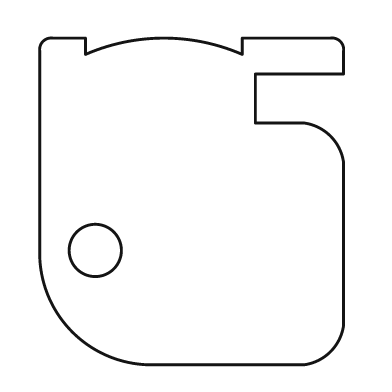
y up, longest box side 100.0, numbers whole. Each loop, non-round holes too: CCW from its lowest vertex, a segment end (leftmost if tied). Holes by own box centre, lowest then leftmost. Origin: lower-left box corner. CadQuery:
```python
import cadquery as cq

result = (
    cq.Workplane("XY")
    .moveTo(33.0, 0.0)
    .lineTo(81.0, 0.0)
    .threePointArc((89.0, 4.0), (93.0, 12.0))
    .lineTo(93.0, 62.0)
    .threePointArc((89.0, 70.0), (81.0, 74.0))
    .lineTo(66.0, 74.0)
    .lineTo(66.0, 89.0)
    .lineTo(93.0, 89.0)
    .lineTo(93.0, 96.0)
    .threePointArc((92.0, 99.0), (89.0, 100.0))
    .lineTo(62.0, 100.0)
    .lineTo(62.0, 95.0)
    .threePointArc((38.0, 100.0), (14.0, 95.0))
    .lineTo(14.0, 100.0)
    .lineTo(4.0, 100.0)
    .threePointArc((1.0, 99.0), (0.0, 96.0))
    .lineTo(0.0, 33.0)
    .threePointArc((10.0, 10.0), (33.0, 0.0))
    .close()
    .moveTo(17.0, 35.0)
    .circle(8.0)
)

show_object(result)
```